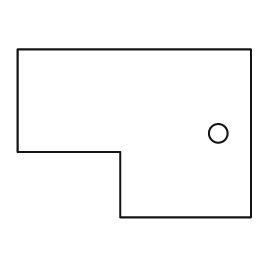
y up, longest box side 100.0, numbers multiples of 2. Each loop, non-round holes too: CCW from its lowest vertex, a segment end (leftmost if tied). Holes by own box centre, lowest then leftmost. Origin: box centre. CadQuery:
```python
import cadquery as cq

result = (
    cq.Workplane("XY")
    .moveTo(-6.0, -36.0)
    .lineTo(50.0, -36.0)
    .lineTo(50.0, 36.0)
    .lineTo(-50.0, 36.0)
    .lineTo(-50.0, -8.0)
    .lineTo(-6.0, -8.0)
    .close()
    .moveTo(36.0, 0.0)
    .circle(4.0)
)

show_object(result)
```